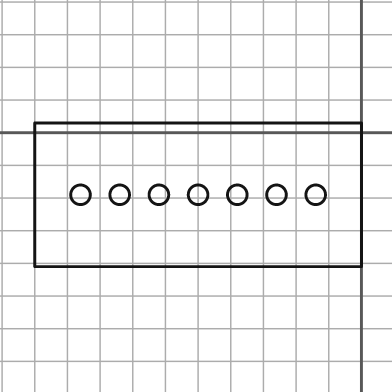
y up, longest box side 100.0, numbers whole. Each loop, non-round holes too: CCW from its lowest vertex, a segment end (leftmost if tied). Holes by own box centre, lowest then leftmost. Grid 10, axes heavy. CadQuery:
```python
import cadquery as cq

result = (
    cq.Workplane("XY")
    .moveTo(-100.0, -41.0)
    .lineTo(0.0, -41.0)
    .lineTo(0.0, 3.0)
    .lineTo(-100.0, 3.0)
    .close()
    .moveTo(-86.0, -19.0)
    .circle(3.0)
    .moveTo(-74.0, -19.0)
    .circle(3.0)
    .moveTo(-62.0, -19.0)
    .circle(3.0)
    .moveTo(-50.0, -19.0)
    .circle(3.0)
    .moveTo(-38.0, -19.0)
    .circle(3.0)
    .moveTo(-26.0, -19.0)
    .circle(3.0)
    .moveTo(-14.0, -19.0)
    .circle(3.0)
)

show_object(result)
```